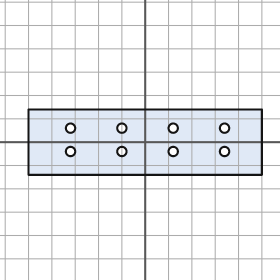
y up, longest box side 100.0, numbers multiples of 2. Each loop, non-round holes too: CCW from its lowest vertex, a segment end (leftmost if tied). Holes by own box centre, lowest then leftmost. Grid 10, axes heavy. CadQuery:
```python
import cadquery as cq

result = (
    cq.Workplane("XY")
    .moveTo(-50.0, -14.0)
    .lineTo(50.0, -14.0)
    .lineTo(50.0, 14.0)
    .lineTo(-50.0, 14.0)
    .close()
    .moveTo(-32.0, -4.0)
    .circle(2.0)
    .moveTo(-10.0, -4.0)
    .circle(2.0)
    .moveTo(12.0, -4.0)
    .circle(2.0)
    .moveTo(34.0, -4.0)
    .circle(2.0)
    .moveTo(-32.0, 6.0)
    .circle(2.0)
    .moveTo(-10.0, 6.0)
    .circle(2.0)
    .moveTo(12.0, 6.0)
    .circle(2.0)
    .moveTo(34.0, 6.0)
    .circle(2.0)
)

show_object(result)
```